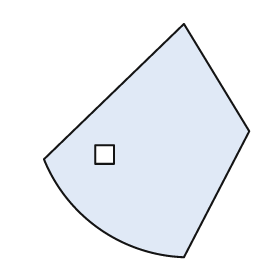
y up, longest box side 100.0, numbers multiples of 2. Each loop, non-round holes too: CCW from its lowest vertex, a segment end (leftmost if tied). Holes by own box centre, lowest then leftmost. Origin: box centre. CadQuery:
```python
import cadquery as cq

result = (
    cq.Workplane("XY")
    .moveTo(16.0, -50.0)
    .lineTo(44.0, 4.0)
    .lineTo(16.0, 50.0)
    .lineTo(-44.0, -8.0)
    .threePointArc((-20.0, -38.0), (16.0, -50.0))
    .close()
    .moveTo(-22.0, -10.0)
    .lineTo(-14.0, -10.0)
    .lineTo(-14.0, -2.0)
    .lineTo(-22.0, -2.0)
    .close()
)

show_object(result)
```